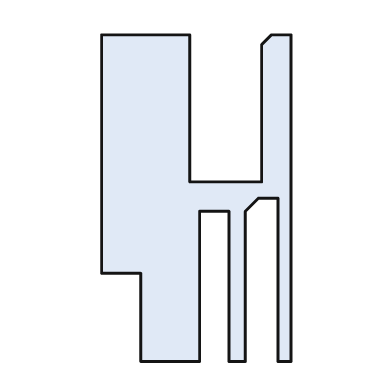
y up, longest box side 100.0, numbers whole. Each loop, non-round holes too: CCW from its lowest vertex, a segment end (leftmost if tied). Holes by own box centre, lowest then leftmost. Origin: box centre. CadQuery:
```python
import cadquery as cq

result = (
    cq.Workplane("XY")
    .moveTo(-17.0, -50.0)
    .lineTo(1.0, -50.0)
    .lineTo(1.0, -4.0)
    .lineTo(10.0, -4.0)
    .lineTo(10.0, -50.0)
    .lineTo(15.0, -50.0)
    .lineTo(15.0, -4.0)
    .lineTo(19.0, 0.0)
    .lineTo(25.0, 0.0)
    .lineTo(25.0, -50.0)
    .lineTo(29.0, -50.0)
    .lineTo(29.0, 50.0)
    .lineTo(23.0, 50.0)
    .lineTo(20.0, 47.0)
    .lineTo(20.0, 5.0)
    .lineTo(-2.0, 5.0)
    .lineTo(-2.0, 50.0)
    .lineTo(-29.0, 50.0)
    .lineTo(-29.0, -23.0)
    .lineTo(-17.0, -23.0)
    .close()
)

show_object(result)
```